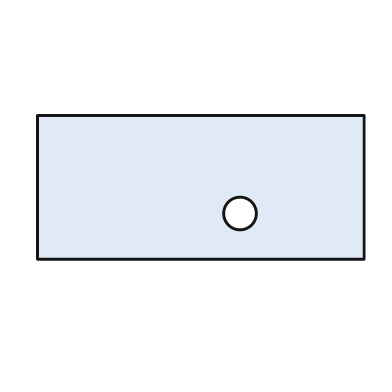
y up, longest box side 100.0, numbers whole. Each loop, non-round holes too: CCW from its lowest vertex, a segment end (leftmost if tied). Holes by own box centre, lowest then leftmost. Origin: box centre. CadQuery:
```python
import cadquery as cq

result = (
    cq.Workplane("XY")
    .moveTo(-50.0, -22.0)
    .lineTo(50.0, -22.0)
    .lineTo(50.0, 22.0)
    .lineTo(-50.0, 22.0)
    .close()
    .moveTo(12.0, -8.0)
    .circle(5.0)
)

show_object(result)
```